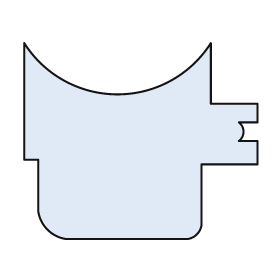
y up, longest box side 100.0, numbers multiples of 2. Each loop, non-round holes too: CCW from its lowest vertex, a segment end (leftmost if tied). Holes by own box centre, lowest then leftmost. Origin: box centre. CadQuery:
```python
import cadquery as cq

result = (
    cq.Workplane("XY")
    .moveTo(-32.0, -42.0)
    .lineTo(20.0, -42.0)
    .threePointArc((24.0, -40.0), (26.0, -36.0))
    .lineTo(26.0, -10.0)
    .lineTo(50.0, -10.0)
    .lineTo(50.0, 0.0)
    .lineTo(42.0, 0.0)
    .threePointArc((44.0, 4.0), (42.0, 8.0))
    .lineTo(50.0, 8.0)
    .lineTo(50.0, 16.0)
    .lineTo(30.0, 16.0)
    .lineTo(30.0, 42.0)
    .threePointArc((-10.0, 20.0), (-50.0, 42.0))
    .lineTo(-50.0, -8.0)
    .lineTo(-44.0, -8.0)
    .lineTo(-44.0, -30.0)
    .threePointArc((-40.0, -38.0), (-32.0, -42.0))
    .close()
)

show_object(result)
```